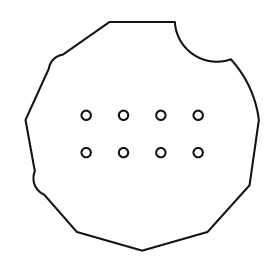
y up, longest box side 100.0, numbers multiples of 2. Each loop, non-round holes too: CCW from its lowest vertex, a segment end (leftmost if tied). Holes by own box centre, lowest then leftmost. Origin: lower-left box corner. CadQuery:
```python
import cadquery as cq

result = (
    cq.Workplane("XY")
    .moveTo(50.0, 0.0)
    .lineTo(78.0, 8.0)
    .lineTo(96.0, 28.0)
    .lineTo(100.0, 56.0)
    .threePointArc((96.0, 70.0), (88.0, 82.0))
    .threePointArc((72.0, 84.0), (64.0, 98.0))
    .lineTo(36.0, 98.0)
    .lineTo(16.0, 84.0)
    .threePointArc((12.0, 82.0), (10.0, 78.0))
    .lineTo(0.0, 56.0)
    .lineTo(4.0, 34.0)
    .threePointArc((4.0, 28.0), (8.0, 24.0))
    .lineTo(22.0, 8.0)
    .close()
    .moveTo(26.0, 42.0)
    .circle(2.0)
    .moveTo(42.0, 42.0)
    .circle(2.0)
    .moveTo(58.0, 42.0)
    .circle(2.0)
    .moveTo(74.0, 42.0)
    .circle(2.0)
    .moveTo(26.0, 58.0)
    .circle(2.0)
    .moveTo(42.0, 58.0)
    .circle(2.0)
    .moveTo(58.0, 58.0)
    .circle(2.0)
    .moveTo(74.0, 58.0)
    .circle(2.0)
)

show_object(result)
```